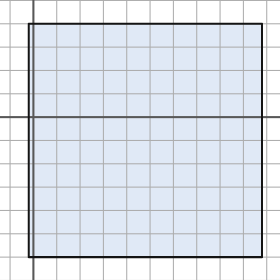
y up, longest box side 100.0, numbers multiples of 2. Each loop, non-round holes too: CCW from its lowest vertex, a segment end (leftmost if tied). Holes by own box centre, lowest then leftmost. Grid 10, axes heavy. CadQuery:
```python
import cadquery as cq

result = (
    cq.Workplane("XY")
    .moveTo(-2.0, -60.0)
    .lineTo(98.0, -60.0)
    .lineTo(98.0, 40.0)
    .lineTo(-2.0, 40.0)
    .close()
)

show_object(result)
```